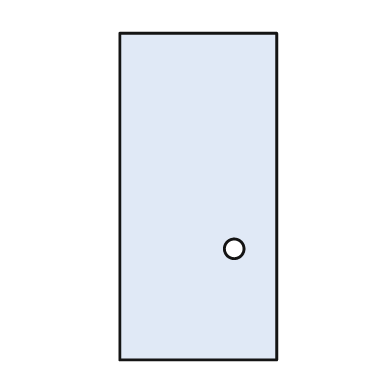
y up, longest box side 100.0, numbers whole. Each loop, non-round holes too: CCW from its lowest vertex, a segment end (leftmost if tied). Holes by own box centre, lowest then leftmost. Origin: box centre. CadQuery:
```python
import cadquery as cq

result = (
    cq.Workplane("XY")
    .moveTo(-24.0, -50.0)
    .lineTo(24.0, -50.0)
    .lineTo(24.0, 50.0)
    .lineTo(-24.0, 50.0)
    .close()
    .moveTo(11.0, -16.0)
    .circle(3.0)
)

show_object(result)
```